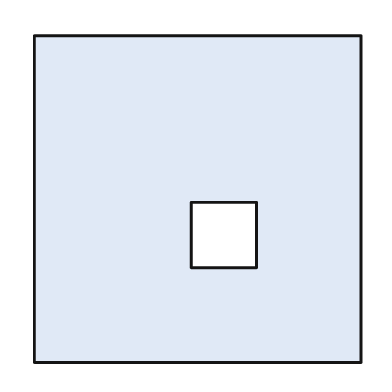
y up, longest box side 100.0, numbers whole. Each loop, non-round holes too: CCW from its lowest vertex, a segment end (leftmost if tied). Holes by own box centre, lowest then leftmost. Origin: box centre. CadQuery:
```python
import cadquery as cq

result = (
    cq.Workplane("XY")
    .moveTo(-50.0, -50.0)
    .lineTo(50.0, -50.0)
    .lineTo(50.0, 50.0)
    .lineTo(-50.0, 50.0)
    .close()
    .moveTo(-2.0, -21.0)
    .lineTo(18.0, -21.0)
    .lineTo(18.0, -1.0)
    .lineTo(-2.0, -1.0)
    .close()
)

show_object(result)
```